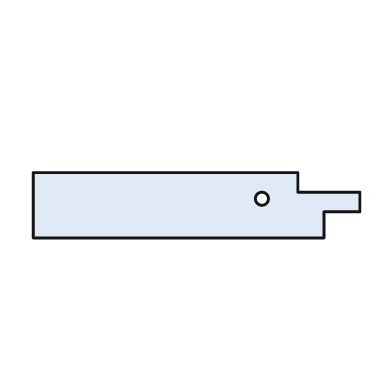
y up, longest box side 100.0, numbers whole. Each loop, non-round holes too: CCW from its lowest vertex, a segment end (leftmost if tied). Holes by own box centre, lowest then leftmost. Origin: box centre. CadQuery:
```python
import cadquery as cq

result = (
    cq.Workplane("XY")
    .moveTo(-50.0, -10.0)
    .lineTo(39.0, -10.0)
    .lineTo(39.0, -2.0)
    .lineTo(50.0, -2.0)
    .lineTo(50.0, 4.0)
    .lineTo(31.0, 4.0)
    .lineTo(31.0, 10.0)
    .lineTo(-50.0, 10.0)
    .close()
    .moveTo(20.0, 2.0)
    .circle(2.0)
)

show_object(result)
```